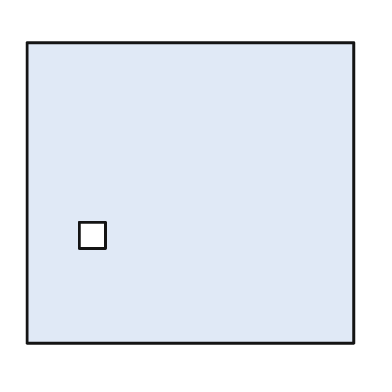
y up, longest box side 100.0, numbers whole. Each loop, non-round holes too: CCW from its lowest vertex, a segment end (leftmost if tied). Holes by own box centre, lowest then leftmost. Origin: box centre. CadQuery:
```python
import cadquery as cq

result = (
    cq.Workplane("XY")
    .moveTo(-50.0, -46.0)
    .lineTo(50.0, -46.0)
    .lineTo(50.0, 46.0)
    .lineTo(-50.0, 46.0)
    .close()
    .moveTo(-34.0, -17.0)
    .lineTo(-26.0, -17.0)
    .lineTo(-26.0, -9.0)
    .lineTo(-34.0, -9.0)
    .close()
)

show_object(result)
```